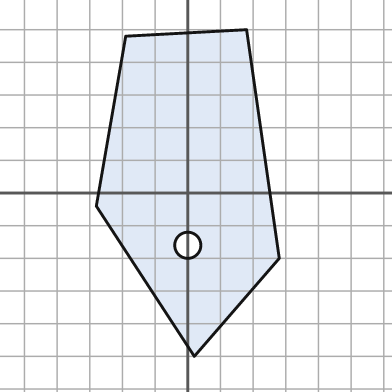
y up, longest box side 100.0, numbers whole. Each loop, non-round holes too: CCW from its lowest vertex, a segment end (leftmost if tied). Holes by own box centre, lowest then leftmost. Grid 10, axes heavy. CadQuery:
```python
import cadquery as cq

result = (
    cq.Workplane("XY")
    .moveTo(2.0, -50.0)
    .lineTo(28.0, -20.0)
    .lineTo(18.0, 50.0)
    .lineTo(-19.0, 48.0)
    .lineTo(-28.0, -4.0)
    .close()
    .moveTo(0.0, -16.0)
    .circle(4.0)
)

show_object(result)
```